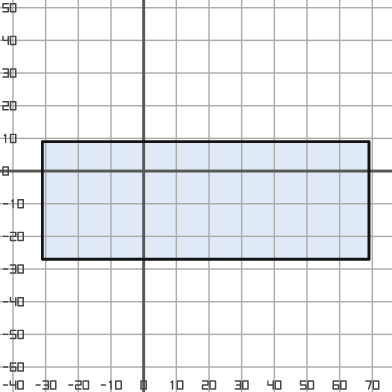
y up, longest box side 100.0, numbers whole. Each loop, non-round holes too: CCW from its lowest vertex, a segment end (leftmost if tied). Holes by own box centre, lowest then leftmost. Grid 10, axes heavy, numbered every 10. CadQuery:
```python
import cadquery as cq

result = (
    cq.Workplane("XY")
    .moveTo(-31.0, -27.0)
    .lineTo(69.0, -27.0)
    .lineTo(69.0, 9.0)
    .lineTo(-31.0, 9.0)
    .close()
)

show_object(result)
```